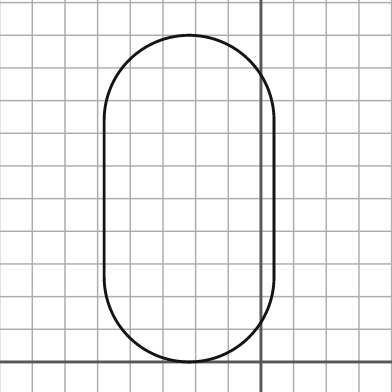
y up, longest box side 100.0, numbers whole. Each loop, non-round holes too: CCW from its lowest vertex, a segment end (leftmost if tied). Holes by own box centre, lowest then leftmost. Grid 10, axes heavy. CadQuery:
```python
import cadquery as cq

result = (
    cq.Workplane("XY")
    .moveTo(-48.0, 26.0)
    .threePointArc((-22.0, 0.0), (4.0, 26.0))
    .lineTo(4.0, 74.0)
    .threePointArc((-22.0, 100.0), (-48.0, 74.0))
    .close()
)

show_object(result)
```